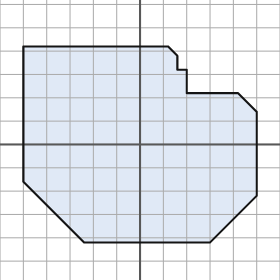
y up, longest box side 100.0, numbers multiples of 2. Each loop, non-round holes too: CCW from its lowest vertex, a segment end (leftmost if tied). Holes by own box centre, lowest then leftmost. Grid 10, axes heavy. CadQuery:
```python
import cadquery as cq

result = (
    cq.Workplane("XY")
    .moveTo(-24.0, -42.0)
    .lineTo(30.0, -42.0)
    .lineTo(50.0, -22.0)
    .lineTo(50.0, 14.0)
    .lineTo(42.0, 22.0)
    .lineTo(20.0, 22.0)
    .lineTo(20.0, 32.0)
    .lineTo(16.0, 32.0)
    .lineTo(16.0, 38.0)
    .lineTo(12.0, 42.0)
    .lineTo(-50.0, 42.0)
    .lineTo(-50.0, -16.0)
    .close()
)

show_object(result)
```